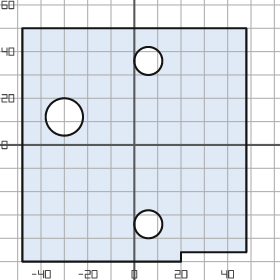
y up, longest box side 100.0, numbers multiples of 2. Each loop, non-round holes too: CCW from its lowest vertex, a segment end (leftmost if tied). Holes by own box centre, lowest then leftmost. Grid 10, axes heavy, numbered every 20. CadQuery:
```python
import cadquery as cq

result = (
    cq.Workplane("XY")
    .moveTo(-48.0, -50.0)
    .lineTo(20.0, -50.0)
    .lineTo(20.0, -46.0)
    .lineTo(48.0, -46.0)
    .lineTo(48.0, 50.0)
    .lineTo(-48.0, 50.0)
    .close()
    .moveTo(6.0, -34.0)
    .circle(6.0)
    .moveTo(-30.0, 12.0)
    .circle(8.0)
    .moveTo(6.0, 36.0)
    .circle(6.0)
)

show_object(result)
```